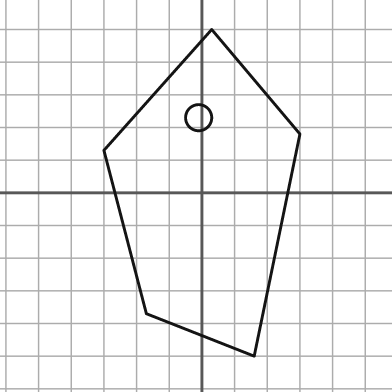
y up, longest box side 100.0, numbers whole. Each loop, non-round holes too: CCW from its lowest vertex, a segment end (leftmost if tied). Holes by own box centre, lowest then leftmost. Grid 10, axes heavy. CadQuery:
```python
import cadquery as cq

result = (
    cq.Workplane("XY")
    .moveTo(16.0, -50.0)
    .lineTo(30.0, 18.0)
    .lineTo(3.0, 50.0)
    .lineTo(-30.0, 13.0)
    .lineTo(-17.0, -37.0)
    .close()
    .moveTo(-1.0, 23.0)
    .circle(4.0)
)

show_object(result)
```